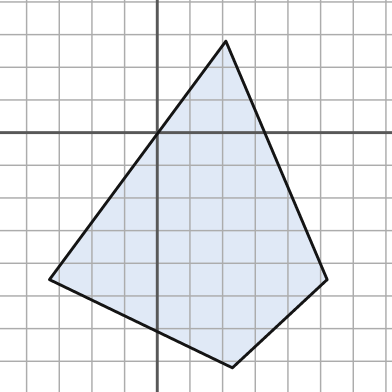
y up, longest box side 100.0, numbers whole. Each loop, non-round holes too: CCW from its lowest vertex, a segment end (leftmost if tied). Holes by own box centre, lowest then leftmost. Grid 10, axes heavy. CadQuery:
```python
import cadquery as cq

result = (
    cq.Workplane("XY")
    .moveTo(23.0, -72.0)
    .lineTo(52.0, -45.0)
    .lineTo(21.0, 28.0)
    .lineTo(-33.0, -45.0)
    .close()
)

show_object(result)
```